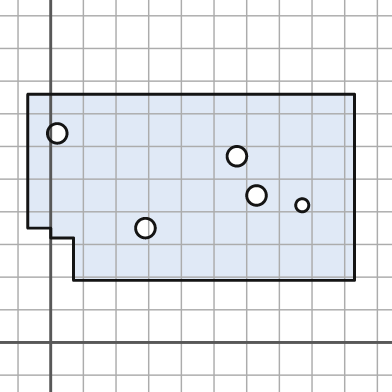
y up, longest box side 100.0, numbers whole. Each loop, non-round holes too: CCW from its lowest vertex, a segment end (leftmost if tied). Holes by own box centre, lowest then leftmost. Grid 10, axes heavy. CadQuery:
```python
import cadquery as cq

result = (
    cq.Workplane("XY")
    .moveTo(7.0, 19.0)
    .lineTo(93.0, 19.0)
    .lineTo(93.0, 76.0)
    .lineTo(-7.0, 76.0)
    .lineTo(-7.0, 35.0)
    .lineTo(0.0, 35.0)
    .lineTo(0.0, 32.0)
    .lineTo(7.0, 32.0)
    .close()
    .moveTo(29.0, 35.0)
    .circle(3.0)
    .moveTo(77.0, 42.0)
    .circle(2.0)
    .moveTo(63.0, 45.0)
    .circle(3.0)
    .moveTo(57.0, 57.0)
    .circle(3.0)
    .moveTo(2.0, 64.0)
    .circle(3.0)
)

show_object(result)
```